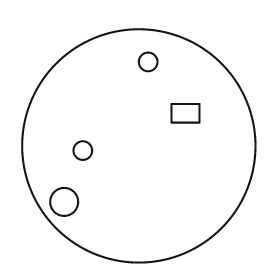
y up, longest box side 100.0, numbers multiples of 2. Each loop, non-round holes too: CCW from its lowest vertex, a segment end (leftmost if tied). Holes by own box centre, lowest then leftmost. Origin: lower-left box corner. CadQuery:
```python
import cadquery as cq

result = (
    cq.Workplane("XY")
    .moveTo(50.0, 50.0)
    .circle(50.0)
    .moveTo(18.0, 26.0)
    .circle(6.0)
    .moveTo(26.0, 48.0)
    .circle(4.0)
    .moveTo(64.0, 60.0)
    .lineTo(76.0, 60.0)
    .lineTo(76.0, 68.0)
    .lineTo(64.0, 68.0)
    .close()
    .moveTo(54.0, 86.0)
    .circle(4.0)
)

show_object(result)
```